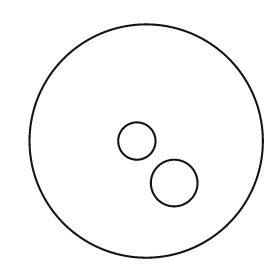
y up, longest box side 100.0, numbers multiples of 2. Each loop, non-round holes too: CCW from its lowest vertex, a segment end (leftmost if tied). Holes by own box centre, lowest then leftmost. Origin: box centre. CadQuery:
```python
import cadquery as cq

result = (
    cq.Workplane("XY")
    .moveTo(0.0, 0.0)
    .circle(50.0)
    .moveTo(12.0, -18.0)
    .circle(10.0)
    .moveTo(-4.0, 0.0)
    .circle(8.0)
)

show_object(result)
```